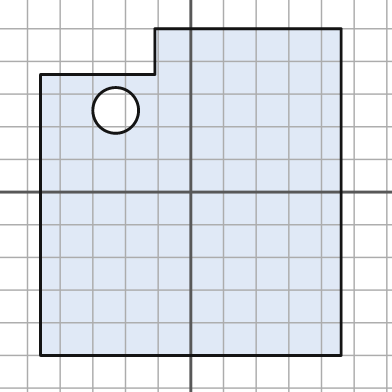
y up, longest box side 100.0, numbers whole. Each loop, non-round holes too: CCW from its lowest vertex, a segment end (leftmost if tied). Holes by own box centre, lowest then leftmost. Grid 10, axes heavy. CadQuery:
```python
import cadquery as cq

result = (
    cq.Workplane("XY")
    .moveTo(-46.0, -50.0)
    .lineTo(46.0, -50.0)
    .lineTo(46.0, 50.0)
    .lineTo(-11.0, 50.0)
    .lineTo(-11.0, 36.0)
    .lineTo(-46.0, 36.0)
    .close()
    .moveTo(-23.0, 25.0)
    .circle(7.0)
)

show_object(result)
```